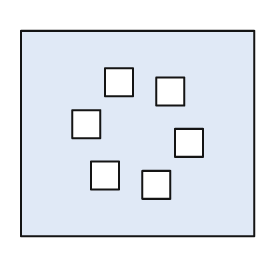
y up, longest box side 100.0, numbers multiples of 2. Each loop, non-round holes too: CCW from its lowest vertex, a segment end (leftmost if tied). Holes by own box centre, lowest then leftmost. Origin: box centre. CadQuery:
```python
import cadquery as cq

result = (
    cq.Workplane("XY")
    .moveTo(-50.0, -44.0)
    .lineTo(50.0, -44.0)
    .lineTo(50.0, 44.0)
    .lineTo(-50.0, 44.0)
    .close()
    .moveTo(2.0, -28.0)
    .lineTo(14.0, -28.0)
    .lineTo(14.0, -16.0)
    .lineTo(2.0, -16.0)
    .close()
    .moveTo(-20.0, -24.0)
    .lineTo(-8.0, -24.0)
    .lineTo(-8.0, -12.0)
    .lineTo(-20.0, -12.0)
    .close()
    .moveTo(16.0, -10.0)
    .lineTo(28.0, -10.0)
    .lineTo(28.0, 2.0)
    .lineTo(16.0, 2.0)
    .close()
    .moveTo(-28.0, -2.0)
    .lineTo(-16.0, -2.0)
    .lineTo(-16.0, 10.0)
    .lineTo(-28.0, 10.0)
    .close()
    .moveTo(8.0, 12.0)
    .lineTo(20.0, 12.0)
    .lineTo(20.0, 24.0)
    .lineTo(8.0, 24.0)
    .close()
    .moveTo(-14.0, 16.0)
    .lineTo(-2.0, 16.0)
    .lineTo(-2.0, 28.0)
    .lineTo(-14.0, 28.0)
    .close()
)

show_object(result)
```